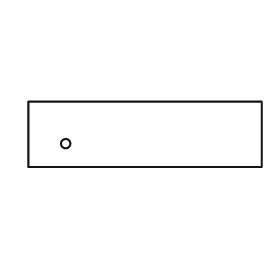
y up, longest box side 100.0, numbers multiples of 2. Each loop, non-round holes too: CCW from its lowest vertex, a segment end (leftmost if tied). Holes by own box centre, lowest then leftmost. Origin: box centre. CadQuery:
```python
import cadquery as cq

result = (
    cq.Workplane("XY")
    .moveTo(-50.0, -14.0)
    .lineTo(50.0, -14.0)
    .lineTo(50.0, 14.0)
    .lineTo(-50.0, 14.0)
    .close()
    .moveTo(-34.0, -4.0)
    .circle(2.0)
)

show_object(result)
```